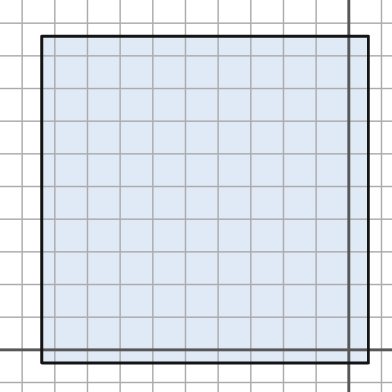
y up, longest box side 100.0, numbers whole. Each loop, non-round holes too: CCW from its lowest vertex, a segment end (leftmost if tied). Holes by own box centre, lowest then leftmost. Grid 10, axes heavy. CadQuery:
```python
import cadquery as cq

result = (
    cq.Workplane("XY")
    .moveTo(-94.0, -4.0)
    .lineTo(6.0, -4.0)
    .lineTo(6.0, 96.0)
    .lineTo(-94.0, 96.0)
    .close()
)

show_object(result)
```